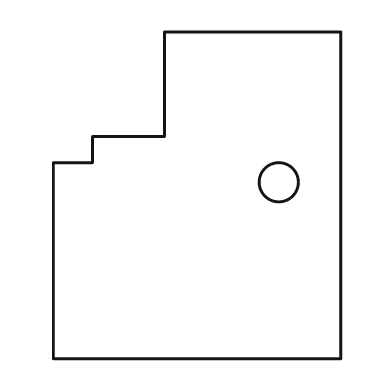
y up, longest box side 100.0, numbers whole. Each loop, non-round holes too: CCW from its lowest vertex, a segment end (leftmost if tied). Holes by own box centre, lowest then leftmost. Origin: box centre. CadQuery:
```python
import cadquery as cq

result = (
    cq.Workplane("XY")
    .moveTo(-44.0, -50.0)
    .lineTo(44.0, -50.0)
    .lineTo(44.0, 50.0)
    .lineTo(-10.0, 50.0)
    .lineTo(-10.0, 18.0)
    .lineTo(-32.0, 18.0)
    .lineTo(-32.0, 10.0)
    .lineTo(-44.0, 10.0)
    .close()
    .moveTo(25.0, 4.0)
    .circle(6.0)
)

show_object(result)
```